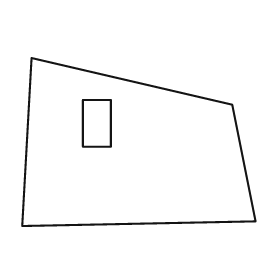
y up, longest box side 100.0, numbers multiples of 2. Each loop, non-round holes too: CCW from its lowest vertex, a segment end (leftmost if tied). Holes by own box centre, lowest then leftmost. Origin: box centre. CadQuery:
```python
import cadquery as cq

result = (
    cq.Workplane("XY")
    .moveTo(-50.0, -36.0)
    .lineTo(50.0, -34.0)
    .lineTo(40.0, 16.0)
    .lineTo(-46.0, 36.0)
    .close()
    .moveTo(-24.0, -2.0)
    .lineTo(-12.0, -2.0)
    .lineTo(-12.0, 18.0)
    .lineTo(-24.0, 18.0)
    .close()
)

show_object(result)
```